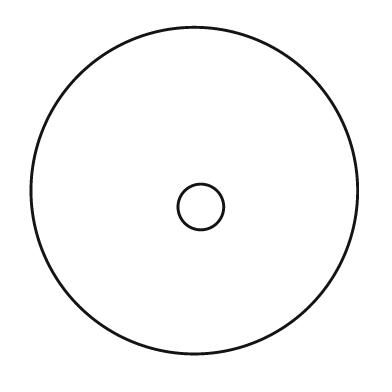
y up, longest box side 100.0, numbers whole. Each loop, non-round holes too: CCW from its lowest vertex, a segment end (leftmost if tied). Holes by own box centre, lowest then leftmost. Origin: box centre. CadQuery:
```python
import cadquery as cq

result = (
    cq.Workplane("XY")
    .moveTo(0.0, 0.0)
    .circle(50.0)
    .moveTo(2.0, -5.0)
    .circle(7.0)
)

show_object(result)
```